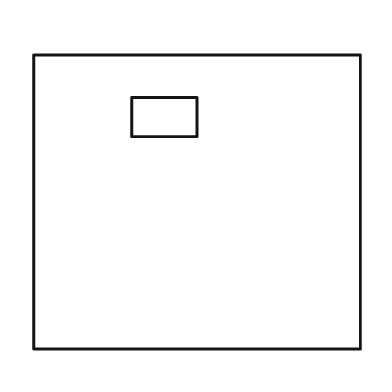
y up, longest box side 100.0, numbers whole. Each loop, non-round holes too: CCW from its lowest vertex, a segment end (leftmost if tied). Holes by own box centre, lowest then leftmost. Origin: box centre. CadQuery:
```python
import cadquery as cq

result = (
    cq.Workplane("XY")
    .moveTo(-50.0, -45.0)
    .lineTo(50.0, -45.0)
    .lineTo(50.0, 45.0)
    .lineTo(-50.0, 45.0)
    .close()
    .moveTo(-20.0, 20.0)
    .lineTo(0.0, 20.0)
    .lineTo(0.0, 32.0)
    .lineTo(-20.0, 32.0)
    .close()
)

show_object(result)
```